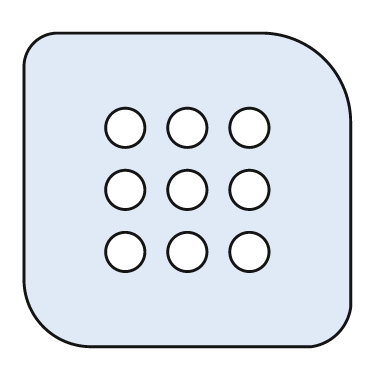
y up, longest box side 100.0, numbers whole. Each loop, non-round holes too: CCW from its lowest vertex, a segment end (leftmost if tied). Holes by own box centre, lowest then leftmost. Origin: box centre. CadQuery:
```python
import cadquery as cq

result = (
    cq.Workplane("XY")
    .moveTo(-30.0, -48.0)
    .lineTo(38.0, -48.0)
    .threePointArc((46.0, -44.0), (50.0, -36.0))
    .lineTo(50.0, 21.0)
    .threePointArc((42.0, 40.0), (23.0, 48.0))
    .lineTo(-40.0, 48.0)
    .threePointArc((-47.0, 45.0), (-50.0, 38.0))
    .lineTo(-50.0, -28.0)
    .threePointArc((-44.0, -42.0), (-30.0, -48.0))
    .close()
    .moveTo(-19.0, -19.0)
    .circle(6.0)
    .moveTo(0.0, -19.0)
    .circle(6.0)
    .moveTo(19.0, -19.0)
    .circle(6.0)
    .moveTo(-19.0, 0.0)
    .circle(6.0)
    .moveTo(0.0, 0.0)
    .circle(6.0)
    .moveTo(19.0, 0.0)
    .circle(6.0)
    .moveTo(-19.0, 19.0)
    .circle(6.0)
    .moveTo(0.0, 19.0)
    .circle(6.0)
    .moveTo(19.0, 19.0)
    .circle(6.0)
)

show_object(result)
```